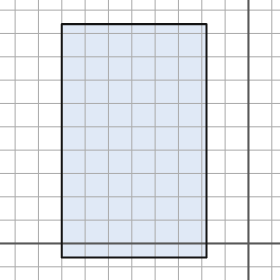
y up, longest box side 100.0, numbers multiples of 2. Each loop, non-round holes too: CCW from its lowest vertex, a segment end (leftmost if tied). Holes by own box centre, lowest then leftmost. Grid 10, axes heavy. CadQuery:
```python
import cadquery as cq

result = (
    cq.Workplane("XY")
    .moveTo(-80.0, -6.0)
    .lineTo(-18.0, -6.0)
    .lineTo(-18.0, 94.0)
    .lineTo(-80.0, 94.0)
    .close()
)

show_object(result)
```